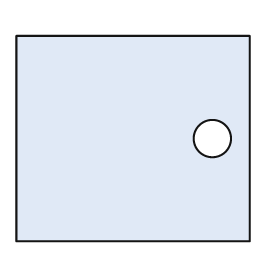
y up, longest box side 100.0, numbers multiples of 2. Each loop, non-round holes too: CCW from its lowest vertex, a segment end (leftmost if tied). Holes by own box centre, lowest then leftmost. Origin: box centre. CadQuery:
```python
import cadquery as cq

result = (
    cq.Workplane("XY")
    .moveTo(-50.0, -44.0)
    .lineTo(50.0, -44.0)
    .lineTo(50.0, 44.0)
    .lineTo(-50.0, 44.0)
    .close()
    .moveTo(34.0, 0.0)
    .circle(8.0)
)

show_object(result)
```